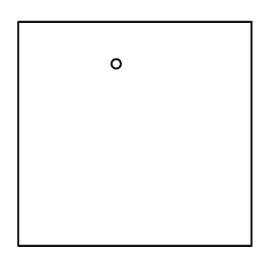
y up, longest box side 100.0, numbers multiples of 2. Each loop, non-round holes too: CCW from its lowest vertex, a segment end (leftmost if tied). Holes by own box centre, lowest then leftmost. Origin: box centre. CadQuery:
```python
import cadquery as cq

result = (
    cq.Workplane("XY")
    .moveTo(-50.0, -48.0)
    .lineTo(50.0, -48.0)
    .lineTo(50.0, 48.0)
    .lineTo(-50.0, 48.0)
    .close()
    .moveTo(-8.0, 30.0)
    .circle(2.0)
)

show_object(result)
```